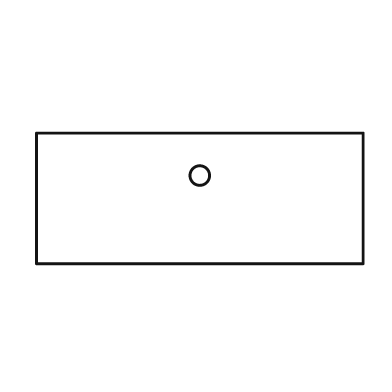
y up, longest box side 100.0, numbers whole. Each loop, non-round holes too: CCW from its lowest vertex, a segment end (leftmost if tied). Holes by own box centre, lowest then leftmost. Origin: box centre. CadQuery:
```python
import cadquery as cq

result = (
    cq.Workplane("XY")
    .moveTo(-50.0, -20.0)
    .lineTo(50.0, -20.0)
    .lineTo(50.0, 20.0)
    .lineTo(-50.0, 20.0)
    .close()
    .moveTo(0.0, 7.0)
    .circle(3.0)
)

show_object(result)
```